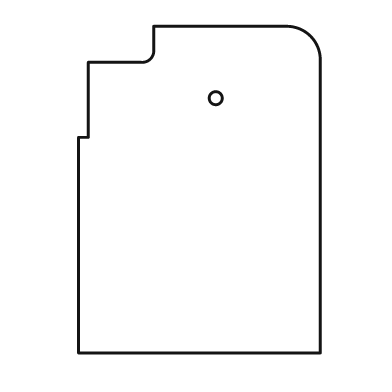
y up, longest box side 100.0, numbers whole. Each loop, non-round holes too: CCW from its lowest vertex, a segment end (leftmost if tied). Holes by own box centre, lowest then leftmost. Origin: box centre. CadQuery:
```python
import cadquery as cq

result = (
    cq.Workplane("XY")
    .moveTo(-37.0, -50.0)
    .lineTo(37.0, -50.0)
    .lineTo(37.0, 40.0)
    .threePointArc((34.0, 47.0), (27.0, 50.0))
    .lineTo(-14.0, 50.0)
    .lineTo(-14.0, 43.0)
    .threePointArc((-15.0, 40.0), (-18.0, 39.0))
    .lineTo(-34.0, 39.0)
    .lineTo(-34.0, 16.0)
    .lineTo(-37.0, 16.0)
    .close()
    .moveTo(5.0, 28.0)
    .circle(2.0)
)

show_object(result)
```